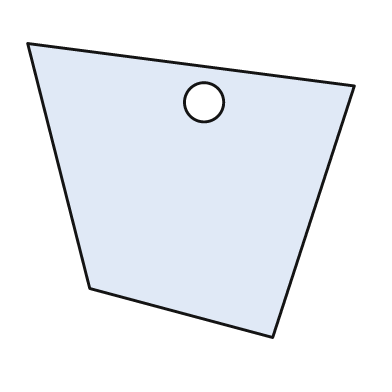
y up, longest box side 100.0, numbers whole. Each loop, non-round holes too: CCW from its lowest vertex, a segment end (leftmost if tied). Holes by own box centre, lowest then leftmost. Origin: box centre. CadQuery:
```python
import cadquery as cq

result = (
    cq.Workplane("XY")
    .moveTo(25.0, -45.0)
    .lineTo(50.0, 32.0)
    .lineTo(-50.0, 45.0)
    .lineTo(-31.0, -30.0)
    .close()
    .moveTo(4.0, 27.0)
    .circle(6.0)
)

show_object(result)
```